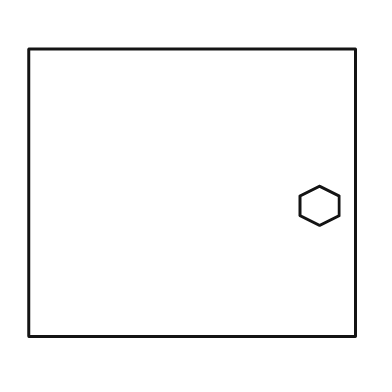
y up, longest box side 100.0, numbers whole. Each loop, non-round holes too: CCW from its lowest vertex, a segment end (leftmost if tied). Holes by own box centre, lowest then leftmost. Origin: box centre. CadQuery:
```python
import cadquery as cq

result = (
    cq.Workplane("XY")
    .moveTo(-50.0, -44.0)
    .lineTo(50.0, -44.0)
    .lineTo(50.0, 44.0)
    .lineTo(-50.0, 44.0)
    .close()
    .moveTo(39.0, -10.0)
    .lineTo(45.0, -7.0)
    .lineTo(45.0, -1.0)
    .lineTo(39.0, 2.0)
    .lineTo(33.0, -1.0)
    .lineTo(33.0, -7.0)
    .close()
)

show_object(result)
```